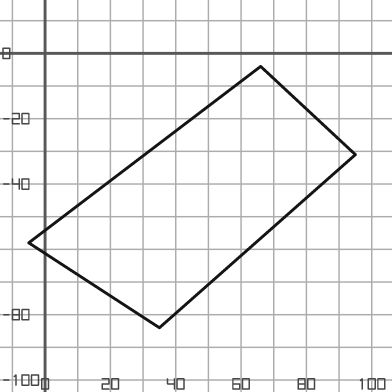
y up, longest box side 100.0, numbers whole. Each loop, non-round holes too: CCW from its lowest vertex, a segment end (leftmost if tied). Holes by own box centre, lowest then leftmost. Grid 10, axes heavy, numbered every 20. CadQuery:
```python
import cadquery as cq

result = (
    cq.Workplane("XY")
    .moveTo(35.0, -84.0)
    .lineTo(95.0, -31.0)
    .lineTo(66.0, -4.0)
    .lineTo(-5.0, -58.0)
    .close()
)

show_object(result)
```